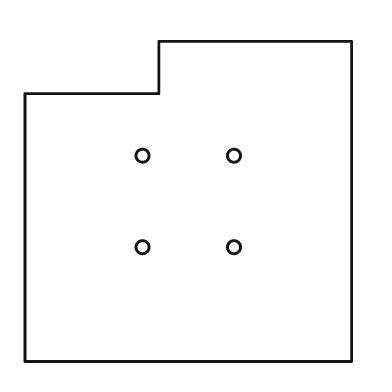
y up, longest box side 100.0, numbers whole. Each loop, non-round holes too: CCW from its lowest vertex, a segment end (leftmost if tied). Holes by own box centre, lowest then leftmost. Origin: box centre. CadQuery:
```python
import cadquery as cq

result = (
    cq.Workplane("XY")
    .moveTo(-50.0, -49.0)
    .lineTo(50.0, -49.0)
    .lineTo(50.0, 49.0)
    .lineTo(-9.0, 49.0)
    .lineTo(-9.0, 33.0)
    .lineTo(-50.0, 33.0)
    .close()
    .moveTo(-14.0, -14.0)
    .circle(2.0)
    .moveTo(14.0, -14.0)
    .circle(2.0)
    .moveTo(-14.0, 14.0)
    .circle(2.0)
    .moveTo(14.0, 14.0)
    .circle(2.0)
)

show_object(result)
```